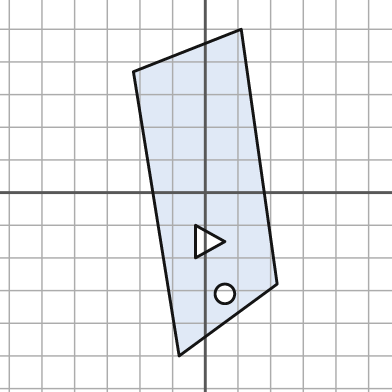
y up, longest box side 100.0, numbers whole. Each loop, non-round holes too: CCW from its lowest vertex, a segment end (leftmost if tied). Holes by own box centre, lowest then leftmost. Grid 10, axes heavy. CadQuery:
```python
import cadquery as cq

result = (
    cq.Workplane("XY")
    .moveTo(-8.0, -50.0)
    .lineTo(22.0, -28.0)
    .lineTo(11.0, 50.0)
    .lineTo(-22.0, 37.0)
    .close()
    .moveTo(6.0, -31.0)
    .circle(3.0)
    .moveTo(-3.0, -20.0)
    .lineTo(6.0, -15.0)
    .lineTo(-3.0, -10.0)
    .close()
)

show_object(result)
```